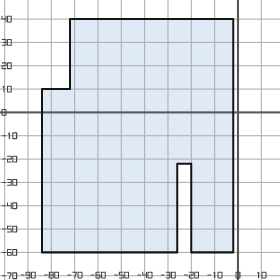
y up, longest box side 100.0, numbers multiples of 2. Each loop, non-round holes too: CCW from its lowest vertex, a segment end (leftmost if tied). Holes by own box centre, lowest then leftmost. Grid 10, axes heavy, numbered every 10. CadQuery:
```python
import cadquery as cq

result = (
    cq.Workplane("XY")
    .moveTo(-84.0, -60.0)
    .lineTo(-26.0, -60.0)
    .lineTo(-26.0, -22.0)
    .lineTo(-20.0, -22.0)
    .lineTo(-20.0, -60.0)
    .lineTo(-2.0, -60.0)
    .lineTo(-2.0, 40.0)
    .lineTo(-72.0, 40.0)
    .lineTo(-72.0, 10.0)
    .lineTo(-84.0, 10.0)
    .close()
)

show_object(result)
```